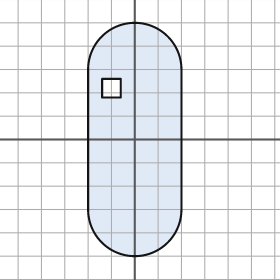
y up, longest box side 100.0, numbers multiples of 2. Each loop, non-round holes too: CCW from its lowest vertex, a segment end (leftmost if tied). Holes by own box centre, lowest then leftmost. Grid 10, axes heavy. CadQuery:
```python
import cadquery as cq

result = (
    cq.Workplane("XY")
    .moveTo(-20.0, -30.0)
    .threePointArc((0.0, -50.0), (20.0, -30.0))
    .lineTo(20.0, 30.0)
    .threePointArc((0.0, 50.0), (-20.0, 30.0))
    .close()
    .moveTo(-14.0, 18.0)
    .lineTo(-6.0, 18.0)
    .lineTo(-6.0, 26.0)
    .lineTo(-14.0, 26.0)
    .close()
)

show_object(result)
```